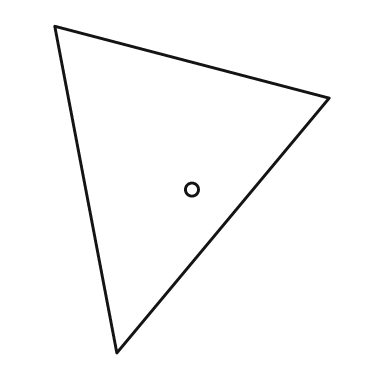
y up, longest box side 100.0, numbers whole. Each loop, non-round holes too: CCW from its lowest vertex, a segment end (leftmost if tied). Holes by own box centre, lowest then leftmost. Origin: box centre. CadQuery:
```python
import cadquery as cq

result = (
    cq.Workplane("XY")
    .moveTo(-23.0, -50.0)
    .lineTo(42.0, 28.0)
    .lineTo(-42.0, 50.0)
    .close()
    .moveTo(0.0, 0.0)
    .circle(2.0)
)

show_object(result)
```